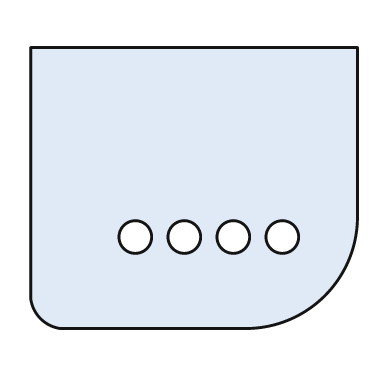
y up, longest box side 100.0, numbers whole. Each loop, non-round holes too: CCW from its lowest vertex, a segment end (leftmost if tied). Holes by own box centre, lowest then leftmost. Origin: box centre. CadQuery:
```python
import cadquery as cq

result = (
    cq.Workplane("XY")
    .moveTo(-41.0, -43.0)
    .lineTo(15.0, -43.0)
    .threePointArc((40.0, -33.0), (50.0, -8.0))
    .lineTo(50.0, 43.0)
    .lineTo(-50.0, 43.0)
    .lineTo(-50.0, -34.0)
    .threePointArc((-47.0, -40.0), (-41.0, -43.0))
    .close()
    .moveTo(-18.0, -15.0)
    .circle(5.0)
    .moveTo(-3.0, -15.0)
    .circle(5.0)
    .moveTo(12.0, -15.0)
    .circle(5.0)
    .moveTo(27.0, -15.0)
    .circle(5.0)
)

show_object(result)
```